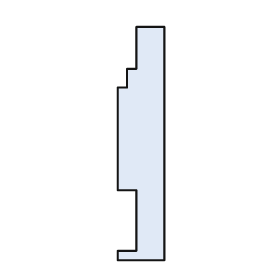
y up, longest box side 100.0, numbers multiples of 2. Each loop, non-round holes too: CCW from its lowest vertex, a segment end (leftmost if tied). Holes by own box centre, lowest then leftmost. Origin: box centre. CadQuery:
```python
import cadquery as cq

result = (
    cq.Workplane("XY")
    .moveTo(-10.0, -50.0)
    .lineTo(10.0, -50.0)
    .lineTo(10.0, 50.0)
    .lineTo(-2.0, 50.0)
    .lineTo(-2.0, 32.0)
    .lineTo(-6.0, 32.0)
    .lineTo(-6.0, 24.0)
    .lineTo(-10.0, 24.0)
    .lineTo(-10.0, -20.0)
    .lineTo(-2.0, -20.0)
    .lineTo(-2.0, -46.0)
    .lineTo(-10.0, -46.0)
    .close()
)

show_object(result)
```